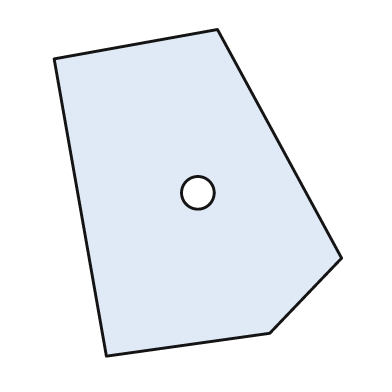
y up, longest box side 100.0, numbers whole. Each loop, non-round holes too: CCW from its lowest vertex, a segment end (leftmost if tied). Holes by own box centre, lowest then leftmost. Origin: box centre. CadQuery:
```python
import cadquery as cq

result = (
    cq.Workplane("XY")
    .moveTo(-28.0, -50.0)
    .lineTo(22.0, -43.0)
    .lineTo(44.0, -20.0)
    .lineTo(6.0, 50.0)
    .lineTo(-44.0, 41.0)
    .close()
    .moveTo(0.0, 0.0)
    .circle(5.0)
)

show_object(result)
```